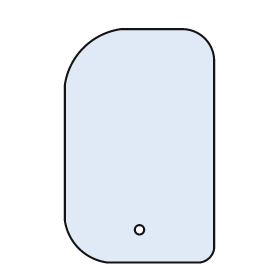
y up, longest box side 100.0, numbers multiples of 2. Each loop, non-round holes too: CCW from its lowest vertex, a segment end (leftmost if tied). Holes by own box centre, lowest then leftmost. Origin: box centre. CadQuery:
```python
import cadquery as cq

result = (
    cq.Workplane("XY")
    .moveTo(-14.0, -50.0)
    .lineTo(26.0, -50.0)
    .threePointArc((30.0, -48.0), (32.0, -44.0))
    .lineTo(32.0, 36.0)
    .threePointArc((28.0, 46.0), (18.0, 50.0))
    .lineTo(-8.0, 50.0)
    .threePointArc((-24.0, 42.0), (-32.0, 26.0))
    .lineTo(-32.0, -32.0)
    .threePointArc((-26.0, -44.0), (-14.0, -50.0))
    .close()
    .moveTo(0.0, -36.0)
    .circle(2.0)
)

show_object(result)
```